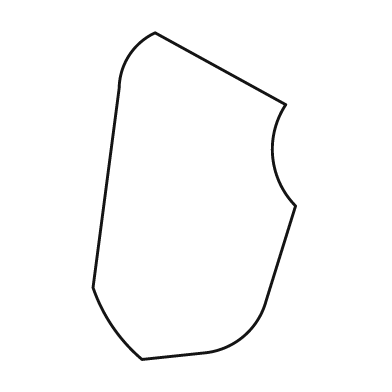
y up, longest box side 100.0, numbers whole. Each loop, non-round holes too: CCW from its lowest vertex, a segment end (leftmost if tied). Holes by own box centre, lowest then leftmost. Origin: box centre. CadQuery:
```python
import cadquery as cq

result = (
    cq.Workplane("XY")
    .moveTo(-16.0, -50.0)
    .lineTo(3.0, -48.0)
    .threePointArc((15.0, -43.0), (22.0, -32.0))
    .lineTo(31.0, -3.0)
    .threePointArc((24.0, 12.0), (28.0, 28.0))
    .lineTo(-12.0, 50.0)
    .threePointArc((-20.0, 43.0), (-23.0, 33.0))
    .lineTo(-31.0, -28.0)
    .threePointArc((-25.0, -40.0), (-16.0, -50.0))
    .close()
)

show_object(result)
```